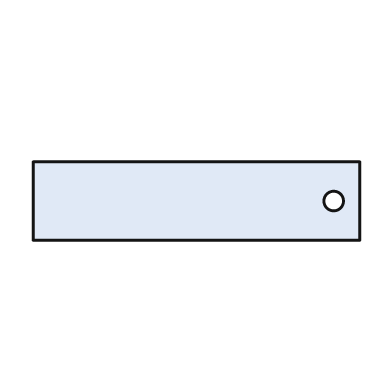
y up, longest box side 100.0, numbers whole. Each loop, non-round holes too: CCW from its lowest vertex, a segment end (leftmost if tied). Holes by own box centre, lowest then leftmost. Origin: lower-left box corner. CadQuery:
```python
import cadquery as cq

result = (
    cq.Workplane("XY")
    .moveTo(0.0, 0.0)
    .lineTo(100.0, 0.0)
    .lineTo(100.0, 24.0)
    .lineTo(0.0, 24.0)
    .close()
    .moveTo(92.0, 12.0)
    .circle(3.0)
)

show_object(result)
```